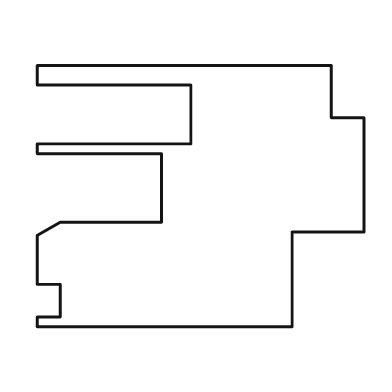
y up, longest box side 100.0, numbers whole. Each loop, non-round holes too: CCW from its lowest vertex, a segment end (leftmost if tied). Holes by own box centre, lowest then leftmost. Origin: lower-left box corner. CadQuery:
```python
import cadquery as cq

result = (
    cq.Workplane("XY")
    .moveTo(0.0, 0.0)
    .lineTo(78.0, 0.0)
    .lineTo(78.0, 29.0)
    .lineTo(100.0, 29.0)
    .lineTo(100.0, 64.0)
    .lineTo(90.0, 64.0)
    .lineTo(90.0, 80.0)
    .lineTo(0.0, 80.0)
    .lineTo(0.0, 74.0)
    .lineTo(47.0, 74.0)
    .lineTo(47.0, 56.0)
    .lineTo(0.0, 56.0)
    .lineTo(0.0, 53.0)
    .lineTo(38.0, 53.0)
    .lineTo(38.0, 32.0)
    .lineTo(7.0, 32.0)
    .lineTo(0.0, 28.0)
    .lineTo(0.0, 13.0)
    .lineTo(7.0, 13.0)
    .lineTo(7.0, 3.0)
    .lineTo(0.0, 3.0)
    .close()
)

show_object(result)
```